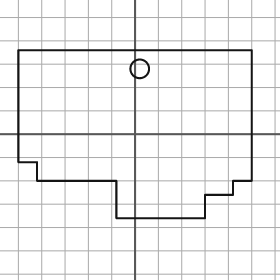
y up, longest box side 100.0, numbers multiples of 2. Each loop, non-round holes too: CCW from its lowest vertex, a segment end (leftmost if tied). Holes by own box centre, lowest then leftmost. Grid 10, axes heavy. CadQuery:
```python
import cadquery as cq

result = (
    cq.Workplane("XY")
    .moveTo(-8.0, -36.0)
    .lineTo(30.0, -36.0)
    .lineTo(30.0, -26.0)
    .lineTo(42.0, -26.0)
    .lineTo(42.0, -20.0)
    .lineTo(50.0, -20.0)
    .lineTo(50.0, 36.0)
    .lineTo(-50.0, 36.0)
    .lineTo(-50.0, -12.0)
    .lineTo(-42.0, -12.0)
    .lineTo(-42.0, -20.0)
    .lineTo(-8.0, -20.0)
    .close()
    .moveTo(2.0, 28.0)
    .circle(4.0)
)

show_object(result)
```